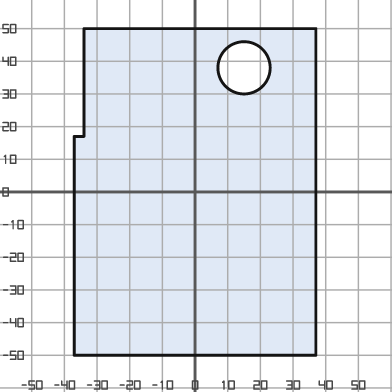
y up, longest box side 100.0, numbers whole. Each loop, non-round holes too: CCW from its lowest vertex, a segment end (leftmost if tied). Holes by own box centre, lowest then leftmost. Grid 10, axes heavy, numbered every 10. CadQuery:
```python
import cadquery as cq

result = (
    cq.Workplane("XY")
    .moveTo(-37.0, -50.0)
    .lineTo(37.0, -50.0)
    .lineTo(37.0, 50.0)
    .lineTo(-34.0, 50.0)
    .lineTo(-34.0, 17.0)
    .lineTo(-37.0, 17.0)
    .close()
    .moveTo(15.0, 38.0)
    .circle(8.0)
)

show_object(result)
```